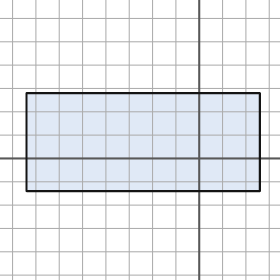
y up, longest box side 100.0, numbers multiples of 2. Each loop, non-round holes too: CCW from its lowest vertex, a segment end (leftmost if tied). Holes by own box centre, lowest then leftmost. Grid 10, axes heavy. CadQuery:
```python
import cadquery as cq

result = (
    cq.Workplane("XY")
    .moveTo(-74.0, -14.0)
    .lineTo(26.0, -14.0)
    .lineTo(26.0, 28.0)
    .lineTo(-74.0, 28.0)
    .close()
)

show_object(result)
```